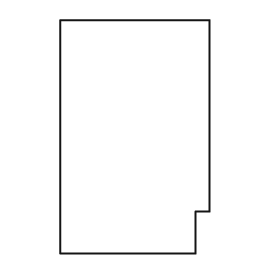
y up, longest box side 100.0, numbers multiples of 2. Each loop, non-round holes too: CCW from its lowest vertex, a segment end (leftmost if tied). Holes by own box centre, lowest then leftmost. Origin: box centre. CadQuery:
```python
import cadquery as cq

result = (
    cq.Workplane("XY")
    .moveTo(-32.0, -50.0)
    .lineTo(26.0, -50.0)
    .lineTo(26.0, -32.0)
    .lineTo(32.0, -32.0)
    .lineTo(32.0, 50.0)
    .lineTo(-32.0, 50.0)
    .close()
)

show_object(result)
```